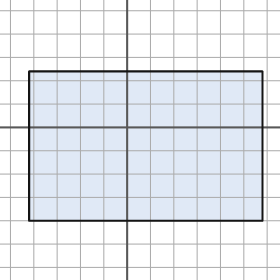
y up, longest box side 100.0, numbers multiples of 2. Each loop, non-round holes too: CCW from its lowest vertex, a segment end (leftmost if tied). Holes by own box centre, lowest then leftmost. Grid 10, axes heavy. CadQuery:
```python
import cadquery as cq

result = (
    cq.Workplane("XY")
    .moveTo(-42.0, -40.0)
    .lineTo(58.0, -40.0)
    .lineTo(58.0, 24.0)
    .lineTo(-42.0, 24.0)
    .close()
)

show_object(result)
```